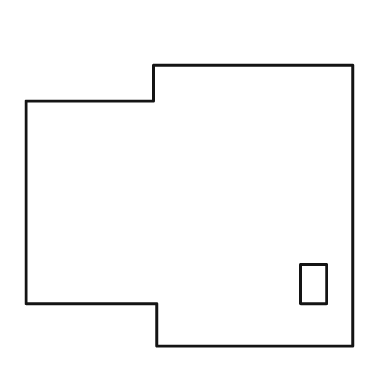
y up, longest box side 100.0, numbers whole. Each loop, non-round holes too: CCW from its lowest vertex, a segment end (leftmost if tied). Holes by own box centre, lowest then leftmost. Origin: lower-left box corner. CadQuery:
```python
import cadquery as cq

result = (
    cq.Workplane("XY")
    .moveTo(40.0, 0.0)
    .lineTo(100.0, 0.0)
    .lineTo(100.0, 86.0)
    .lineTo(39.0, 86.0)
    .lineTo(39.0, 75.0)
    .lineTo(0.0, 75.0)
    .lineTo(0.0, 13.0)
    .lineTo(40.0, 13.0)
    .close()
    .moveTo(84.0, 13.0)
    .lineTo(92.0, 13.0)
    .lineTo(92.0, 25.0)
    .lineTo(84.0, 25.0)
    .close()
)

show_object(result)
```